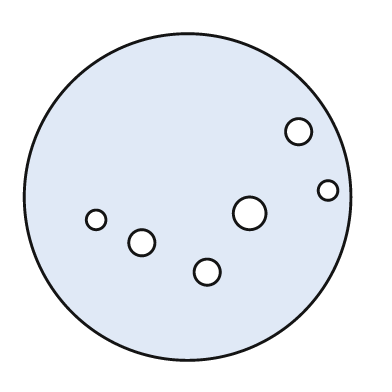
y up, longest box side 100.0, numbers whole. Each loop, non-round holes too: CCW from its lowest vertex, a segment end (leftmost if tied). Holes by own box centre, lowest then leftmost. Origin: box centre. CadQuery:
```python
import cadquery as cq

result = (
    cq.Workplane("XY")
    .moveTo(0.0, 0.0)
    .circle(50.0)
    .moveTo(6.0, -23.0)
    .circle(4.0)
    .moveTo(-14.0, -14.0)
    .circle(4.0)
    .moveTo(-28.0, -7.0)
    .circle(3.0)
    .moveTo(19.0, -5.0)
    .circle(5.0)
    .moveTo(43.0, 2.0)
    .circle(3.0)
    .moveTo(34.0, 20.0)
    .circle(4.0)
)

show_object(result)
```